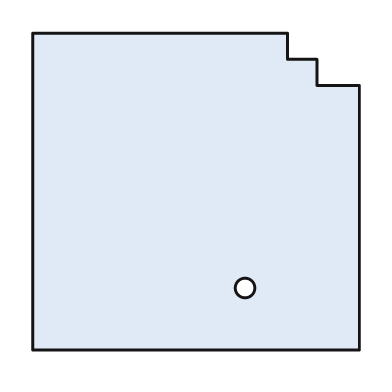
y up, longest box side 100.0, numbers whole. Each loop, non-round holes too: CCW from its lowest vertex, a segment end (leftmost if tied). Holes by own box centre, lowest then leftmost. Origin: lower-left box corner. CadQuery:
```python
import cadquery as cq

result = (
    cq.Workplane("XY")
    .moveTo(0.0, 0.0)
    .lineTo(100.0, 0.0)
    .lineTo(100.0, 81.0)
    .lineTo(87.0, 81.0)
    .lineTo(87.0, 89.0)
    .lineTo(78.0, 89.0)
    .lineTo(78.0, 97.0)
    .lineTo(0.0, 97.0)
    .close()
    .moveTo(65.0, 19.0)
    .circle(3.0)
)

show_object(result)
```